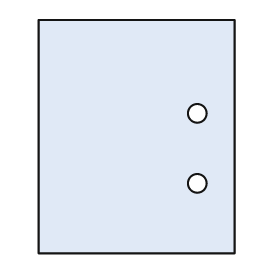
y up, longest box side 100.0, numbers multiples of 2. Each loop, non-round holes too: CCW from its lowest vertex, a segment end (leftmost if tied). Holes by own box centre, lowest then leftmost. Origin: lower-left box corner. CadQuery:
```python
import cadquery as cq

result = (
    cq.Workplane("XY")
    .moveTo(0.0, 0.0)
    .lineTo(84.0, 0.0)
    .lineTo(84.0, 100.0)
    .lineTo(0.0, 100.0)
    .close()
    .moveTo(68.0, 30.0)
    .circle(4.0)
    .moveTo(68.0, 60.0)
    .circle(4.0)
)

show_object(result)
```